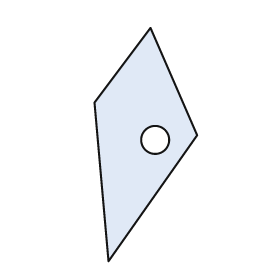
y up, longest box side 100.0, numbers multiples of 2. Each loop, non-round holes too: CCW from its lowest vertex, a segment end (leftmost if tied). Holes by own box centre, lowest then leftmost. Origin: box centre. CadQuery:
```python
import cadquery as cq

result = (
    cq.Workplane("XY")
    .moveTo(-16.0, -50.0)
    .lineTo(22.0, 4.0)
    .lineTo(2.0, 50.0)
    .lineTo(-22.0, 18.0)
    .close()
    .moveTo(4.0, 2.0)
    .circle(6.0)
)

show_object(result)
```